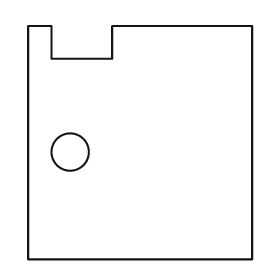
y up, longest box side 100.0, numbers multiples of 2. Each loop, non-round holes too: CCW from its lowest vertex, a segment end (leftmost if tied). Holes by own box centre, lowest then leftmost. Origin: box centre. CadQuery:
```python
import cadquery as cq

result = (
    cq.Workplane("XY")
    .moveTo(-48.0, -50.0)
    .lineTo(48.0, -50.0)
    .lineTo(48.0, 50.0)
    .lineTo(-12.0, 50.0)
    .lineTo(-12.0, 36.0)
    .lineTo(-38.0, 36.0)
    .lineTo(-38.0, 50.0)
    .lineTo(-48.0, 50.0)
    .close()
    .moveTo(-30.0, -4.0)
    .circle(8.0)
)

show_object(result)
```